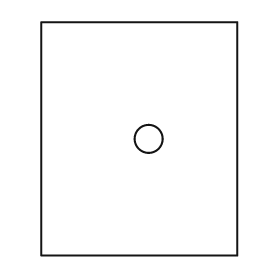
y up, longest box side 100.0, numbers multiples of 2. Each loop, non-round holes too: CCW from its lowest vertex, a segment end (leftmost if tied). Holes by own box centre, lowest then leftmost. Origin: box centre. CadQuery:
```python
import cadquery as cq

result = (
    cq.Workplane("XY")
    .moveTo(-42.0, -50.0)
    .lineTo(42.0, -50.0)
    .lineTo(42.0, 50.0)
    .lineTo(-42.0, 50.0)
    .close()
    .moveTo(4.0, 0.0)
    .circle(6.0)
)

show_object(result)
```